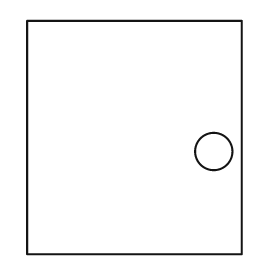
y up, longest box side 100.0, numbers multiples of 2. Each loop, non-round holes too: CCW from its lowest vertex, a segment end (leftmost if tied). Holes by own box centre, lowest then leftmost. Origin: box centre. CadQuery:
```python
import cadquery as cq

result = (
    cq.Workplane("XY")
    .moveTo(-46.0, -50.0)
    .lineTo(46.0, -50.0)
    .lineTo(46.0, 50.0)
    .lineTo(-46.0, 50.0)
    .close()
    .moveTo(34.0, -6.0)
    .circle(8.0)
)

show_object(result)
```